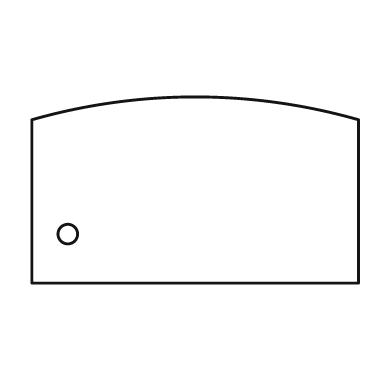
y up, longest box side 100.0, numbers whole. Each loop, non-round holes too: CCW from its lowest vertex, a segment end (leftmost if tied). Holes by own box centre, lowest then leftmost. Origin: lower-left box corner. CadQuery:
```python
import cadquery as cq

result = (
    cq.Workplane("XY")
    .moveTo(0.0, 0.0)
    .lineTo(100.0, 0.0)
    .lineTo(100.0, 50.0)
    .threePointArc((50.0, 57.0), (0.0, 50.0))
    .close()
    .moveTo(11.0, 15.0)
    .circle(3.0)
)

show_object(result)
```